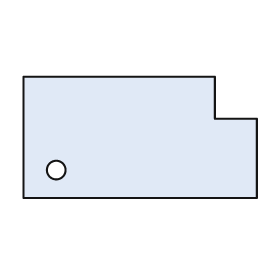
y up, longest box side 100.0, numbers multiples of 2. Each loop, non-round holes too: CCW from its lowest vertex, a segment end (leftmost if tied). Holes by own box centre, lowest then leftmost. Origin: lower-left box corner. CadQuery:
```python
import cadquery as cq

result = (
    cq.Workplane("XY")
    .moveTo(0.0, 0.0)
    .lineTo(100.0, 0.0)
    .lineTo(100.0, 34.0)
    .lineTo(82.0, 34.0)
    .lineTo(82.0, 52.0)
    .lineTo(0.0, 52.0)
    .close()
    .moveTo(14.0, 12.0)
    .circle(4.0)
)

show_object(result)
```